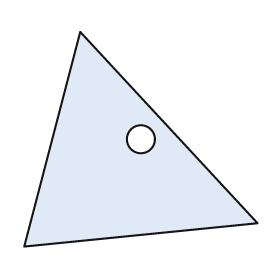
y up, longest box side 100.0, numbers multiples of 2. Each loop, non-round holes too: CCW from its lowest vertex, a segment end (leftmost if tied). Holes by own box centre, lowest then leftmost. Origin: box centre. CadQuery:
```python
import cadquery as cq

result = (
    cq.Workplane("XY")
    .moveTo(-50.0, -46.0)
    .lineTo(50.0, -36.0)
    .lineTo(-26.0, 46.0)
    .close()
    .moveTo(0.0, 0.0)
    .circle(6.0)
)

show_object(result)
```